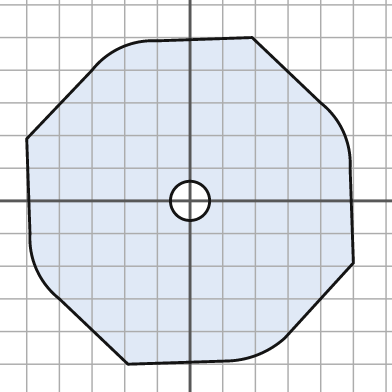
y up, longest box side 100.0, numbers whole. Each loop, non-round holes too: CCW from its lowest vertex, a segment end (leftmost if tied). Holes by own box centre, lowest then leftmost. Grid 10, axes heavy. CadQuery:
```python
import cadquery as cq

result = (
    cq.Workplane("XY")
    .moveTo(-19.0, -50.0)
    .lineTo(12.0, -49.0)
    .threePointArc((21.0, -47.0), (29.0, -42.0))
    .lineTo(50.0, -19.0)
    .lineTo(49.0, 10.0)
    .threePointArc((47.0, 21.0), (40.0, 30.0))
    .lineTo(19.0, 50.0)
    .lineTo(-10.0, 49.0)
    .threePointArc((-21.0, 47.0), (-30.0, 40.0))
    .lineTo(-50.0, 19.0)
    .lineTo(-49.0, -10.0)
    .threePointArc((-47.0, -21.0), (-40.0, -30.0))
    .close()
    .moveTo(0.0, 0.0)
    .circle(6.0)
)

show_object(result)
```